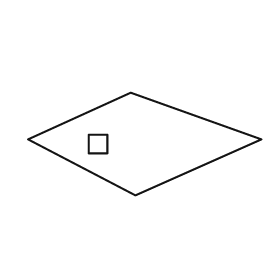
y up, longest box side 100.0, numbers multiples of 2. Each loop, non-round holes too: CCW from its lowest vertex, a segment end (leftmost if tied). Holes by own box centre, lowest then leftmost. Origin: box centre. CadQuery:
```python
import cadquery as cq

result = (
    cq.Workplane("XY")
    .moveTo(-4.0, -22.0)
    .lineTo(50.0, 2.0)
    .lineTo(-6.0, 22.0)
    .lineTo(-50.0, 2.0)
    .close()
    .moveTo(-24.0, -4.0)
    .lineTo(-16.0, -4.0)
    .lineTo(-16.0, 4.0)
    .lineTo(-24.0, 4.0)
    .close()
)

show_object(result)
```